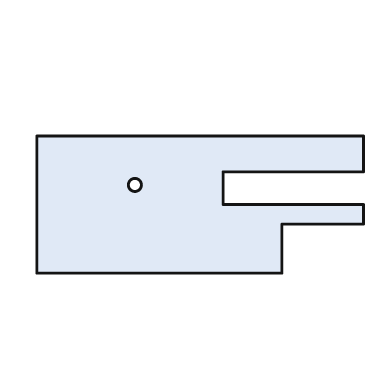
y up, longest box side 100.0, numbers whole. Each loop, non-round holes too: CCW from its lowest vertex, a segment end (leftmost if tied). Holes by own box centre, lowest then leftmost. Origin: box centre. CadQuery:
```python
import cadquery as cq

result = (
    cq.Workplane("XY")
    .moveTo(-50.0, -21.0)
    .lineTo(25.0, -21.0)
    .lineTo(25.0, -6.0)
    .lineTo(50.0, -6.0)
    .lineTo(50.0, 0.0)
    .lineTo(7.0, 0.0)
    .lineTo(7.0, 10.0)
    .lineTo(50.0, 10.0)
    .lineTo(50.0, 21.0)
    .lineTo(-50.0, 21.0)
    .close()
    .moveTo(-20.0, 6.0)
    .circle(2.0)
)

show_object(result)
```